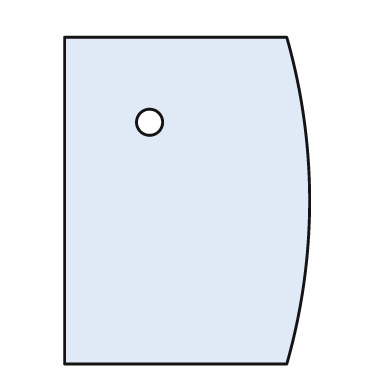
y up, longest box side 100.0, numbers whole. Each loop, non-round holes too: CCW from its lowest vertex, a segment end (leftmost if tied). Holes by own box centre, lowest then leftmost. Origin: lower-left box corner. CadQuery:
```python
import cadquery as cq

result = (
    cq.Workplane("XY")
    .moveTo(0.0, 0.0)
    .lineTo(68.0, 0.0)
    .threePointArc((75.0, 50.0), (68.0, 100.0))
    .lineTo(0.0, 100.0)
    .close()
    .moveTo(26.0, 74.0)
    .circle(4.0)
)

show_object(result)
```